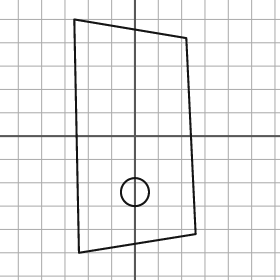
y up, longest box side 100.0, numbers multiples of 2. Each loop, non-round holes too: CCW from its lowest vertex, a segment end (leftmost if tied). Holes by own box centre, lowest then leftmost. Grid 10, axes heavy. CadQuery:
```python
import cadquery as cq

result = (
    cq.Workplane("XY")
    .moveTo(-24.0, -50.0)
    .lineTo(26.0, -42.0)
    .lineTo(22.0, 42.0)
    .lineTo(-26.0, 50.0)
    .close()
    .moveTo(0.0, -24.0)
    .circle(6.0)
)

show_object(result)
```